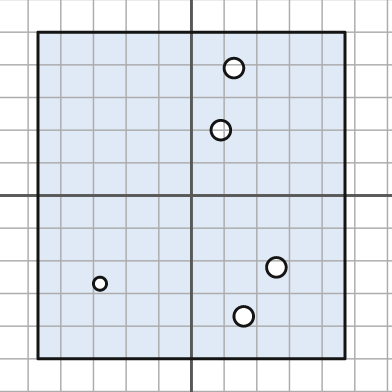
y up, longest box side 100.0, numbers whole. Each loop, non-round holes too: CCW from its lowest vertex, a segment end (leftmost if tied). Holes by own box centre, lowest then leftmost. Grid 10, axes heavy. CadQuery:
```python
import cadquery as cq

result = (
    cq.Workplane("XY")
    .moveTo(-47.0, -50.0)
    .lineTo(47.0, -50.0)
    .lineTo(47.0, 50.0)
    .lineTo(-47.0, 50.0)
    .close()
    .moveTo(16.0, -37.0)
    .circle(3.0)
    .moveTo(-28.0, -27.0)
    .circle(2.0)
    .moveTo(26.0, -22.0)
    .circle(3.0)
    .moveTo(9.0, 20.0)
    .circle(3.0)
    .moveTo(13.0, 39.0)
    .circle(3.0)
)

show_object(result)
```